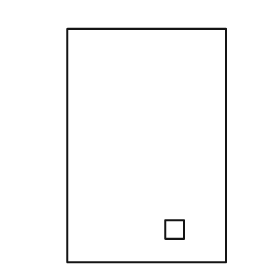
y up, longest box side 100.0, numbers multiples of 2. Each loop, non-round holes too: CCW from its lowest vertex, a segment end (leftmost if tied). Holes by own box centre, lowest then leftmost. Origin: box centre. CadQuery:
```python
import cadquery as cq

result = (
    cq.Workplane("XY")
    .moveTo(-34.0, -50.0)
    .lineTo(34.0, -50.0)
    .lineTo(34.0, 50.0)
    .lineTo(-34.0, 50.0)
    .close()
    .moveTo(8.0, -40.0)
    .lineTo(16.0, -40.0)
    .lineTo(16.0, -32.0)
    .lineTo(8.0, -32.0)
    .close()
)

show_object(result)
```